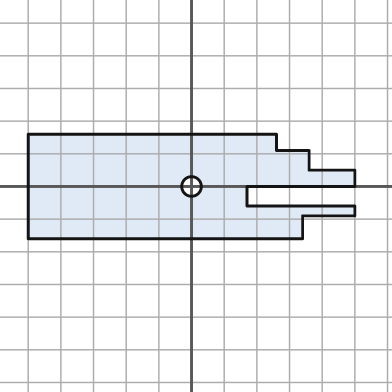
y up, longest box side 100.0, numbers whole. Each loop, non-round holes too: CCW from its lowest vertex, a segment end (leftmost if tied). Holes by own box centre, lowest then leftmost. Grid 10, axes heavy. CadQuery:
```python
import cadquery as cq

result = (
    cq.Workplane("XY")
    .moveTo(-50.0, -16.0)
    .lineTo(34.0, -16.0)
    .lineTo(34.0, -9.0)
    .lineTo(50.0, -9.0)
    .lineTo(50.0, -6.0)
    .lineTo(17.0, -6.0)
    .lineTo(17.0, 0.0)
    .lineTo(50.0, 0.0)
    .lineTo(50.0, 5.0)
    .lineTo(36.0, 5.0)
    .lineTo(36.0, 11.0)
    .lineTo(26.0, 11.0)
    .lineTo(26.0, 16.0)
    .lineTo(-50.0, 16.0)
    .close()
    .moveTo(0.0, 0.0)
    .circle(3.0)
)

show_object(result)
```